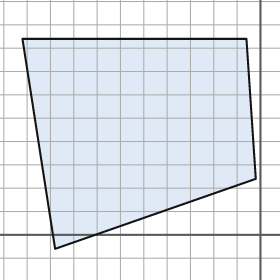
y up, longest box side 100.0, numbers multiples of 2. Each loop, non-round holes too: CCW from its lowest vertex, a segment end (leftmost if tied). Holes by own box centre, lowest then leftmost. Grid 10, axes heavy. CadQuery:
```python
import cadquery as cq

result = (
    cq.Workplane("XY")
    .moveTo(-88.0, -6.0)
    .lineTo(-2.0, 24.0)
    .lineTo(-6.0, 84.0)
    .lineTo(-102.0, 84.0)
    .close()
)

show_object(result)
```